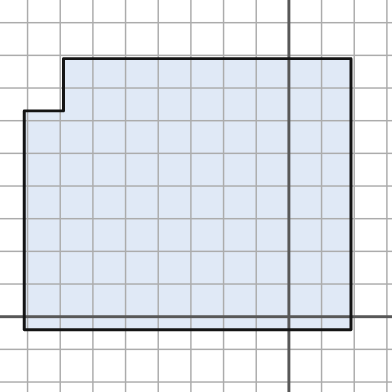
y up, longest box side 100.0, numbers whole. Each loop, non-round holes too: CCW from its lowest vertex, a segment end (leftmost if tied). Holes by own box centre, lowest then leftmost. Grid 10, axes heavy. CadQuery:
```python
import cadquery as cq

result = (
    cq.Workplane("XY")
    .moveTo(-81.0, -4.0)
    .lineTo(19.0, -4.0)
    .lineTo(19.0, 79.0)
    .lineTo(-69.0, 79.0)
    .lineTo(-69.0, 63.0)
    .lineTo(-81.0, 63.0)
    .close()
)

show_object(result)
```